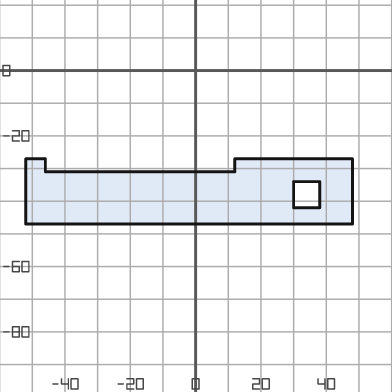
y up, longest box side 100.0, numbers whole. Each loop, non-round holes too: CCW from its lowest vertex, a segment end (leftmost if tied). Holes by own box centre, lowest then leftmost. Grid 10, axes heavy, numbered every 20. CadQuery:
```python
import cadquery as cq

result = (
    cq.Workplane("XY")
    .moveTo(-52.0, -47.0)
    .lineTo(48.0, -47.0)
    .lineTo(48.0, -27.0)
    .lineTo(12.0, -27.0)
    .lineTo(12.0, -31.0)
    .lineTo(-46.0, -31.0)
    .lineTo(-46.0, -27.0)
    .lineTo(-52.0, -27.0)
    .close()
    .moveTo(30.0, -42.0)
    .lineTo(38.0, -42.0)
    .lineTo(38.0, -34.0)
    .lineTo(30.0, -34.0)
    .close()
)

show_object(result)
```